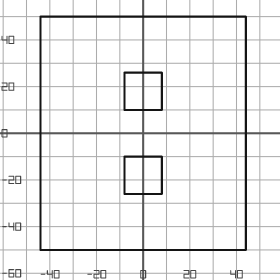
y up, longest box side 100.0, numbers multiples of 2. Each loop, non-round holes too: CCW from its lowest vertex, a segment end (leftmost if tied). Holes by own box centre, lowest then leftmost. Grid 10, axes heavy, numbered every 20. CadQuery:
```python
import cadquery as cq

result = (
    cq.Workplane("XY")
    .moveTo(-44.0, -50.0)
    .lineTo(44.0, -50.0)
    .lineTo(44.0, 50.0)
    .lineTo(-44.0, 50.0)
    .close()
    .moveTo(-8.0, -26.0)
    .lineTo(8.0, -26.0)
    .lineTo(8.0, -10.0)
    .lineTo(-8.0, -10.0)
    .close()
    .moveTo(-8.0, 10.0)
    .lineTo(8.0, 10.0)
    .lineTo(8.0, 26.0)
    .lineTo(-8.0, 26.0)
    .close()
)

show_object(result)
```